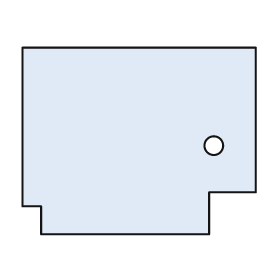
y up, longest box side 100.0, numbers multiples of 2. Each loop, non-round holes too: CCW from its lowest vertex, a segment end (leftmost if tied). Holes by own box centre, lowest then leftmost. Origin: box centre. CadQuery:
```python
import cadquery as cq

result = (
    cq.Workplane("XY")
    .moveTo(-42.0, -40.0)
    .lineTo(30.0, -40.0)
    .lineTo(30.0, -22.0)
    .lineTo(50.0, -22.0)
    .lineTo(50.0, 40.0)
    .lineTo(-50.0, 40.0)
    .lineTo(-50.0, -28.0)
    .lineTo(-42.0, -28.0)
    .close()
    .moveTo(32.0, -2.0)
    .circle(4.0)
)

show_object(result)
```